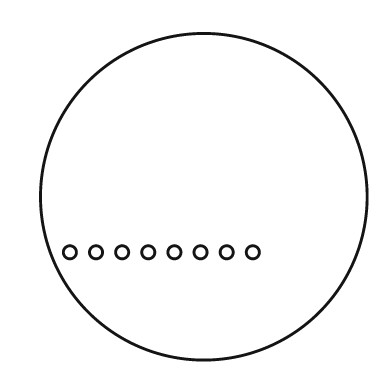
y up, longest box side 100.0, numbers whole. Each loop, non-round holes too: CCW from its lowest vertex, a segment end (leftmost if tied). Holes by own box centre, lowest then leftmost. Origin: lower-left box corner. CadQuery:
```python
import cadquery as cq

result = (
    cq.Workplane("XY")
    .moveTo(50.0, 50.0)
    .circle(50.0)
    .moveTo(9.0, 33.0)
    .circle(2.0)
    .moveTo(17.0, 33.0)
    .circle(2.0)
    .moveTo(25.0, 33.0)
    .circle(2.0)
    .moveTo(33.0, 33.0)
    .circle(2.0)
    .moveTo(41.0, 33.0)
    .circle(2.0)
    .moveTo(49.0, 33.0)
    .circle(2.0)
    .moveTo(57.0, 33.0)
    .circle(2.0)
    .moveTo(65.0, 33.0)
    .circle(2.0)
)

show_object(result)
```